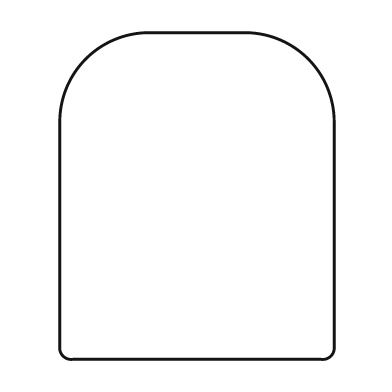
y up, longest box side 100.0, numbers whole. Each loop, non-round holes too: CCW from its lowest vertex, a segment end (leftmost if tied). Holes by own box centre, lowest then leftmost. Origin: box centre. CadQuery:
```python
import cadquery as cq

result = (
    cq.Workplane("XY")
    .moveTo(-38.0, -50.0)
    .lineTo(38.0, -50.0)
    .threePointArc((41.0, -49.0), (42.0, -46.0))
    .lineTo(42.0, 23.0)
    .threePointArc((34.0, 42.0), (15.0, 50.0))
    .lineTo(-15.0, 50.0)
    .threePointArc((-34.0, 42.0), (-42.0, 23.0))
    .lineTo(-42.0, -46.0)
    .threePointArc((-41.0, -49.0), (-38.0, -50.0))
    .close()
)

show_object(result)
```